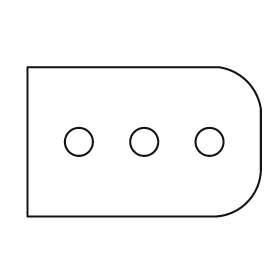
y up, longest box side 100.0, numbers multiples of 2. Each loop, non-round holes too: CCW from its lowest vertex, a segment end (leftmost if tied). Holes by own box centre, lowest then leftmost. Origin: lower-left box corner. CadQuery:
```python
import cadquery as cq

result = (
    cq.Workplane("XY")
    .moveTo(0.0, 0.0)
    .lineTo(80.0, 0.0)
    .threePointArc((94.0, 6.0), (100.0, 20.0))
    .lineTo(100.0, 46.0)
    .threePointArc((94.0, 58.0), (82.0, 64.0))
    .lineTo(0.0, 64.0)
    .close()
    .moveTo(22.0, 32.0)
    .circle(6.0)
    .moveTo(50.0, 32.0)
    .circle(6.0)
    .moveTo(78.0, 32.0)
    .circle(6.0)
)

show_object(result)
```